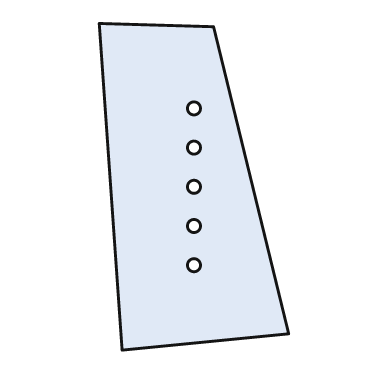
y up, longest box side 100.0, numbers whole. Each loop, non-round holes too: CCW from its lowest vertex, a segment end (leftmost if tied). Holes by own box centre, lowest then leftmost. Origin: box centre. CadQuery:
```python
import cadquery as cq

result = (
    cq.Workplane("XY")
    .moveTo(-22.0, -50.0)
    .lineTo(29.0, -45.0)
    .lineTo(6.0, 49.0)
    .lineTo(-29.0, 50.0)
    .close()
    .moveTo(0.0, -24.0)
    .circle(2.0)
    .moveTo(0.0, -12.0)
    .circle(2.0)
    .moveTo(0.0, 0.0)
    .circle(2.0)
    .moveTo(0.0, 12.0)
    .circle(2.0)
    .moveTo(0.0, 24.0)
    .circle(2.0)
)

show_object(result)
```